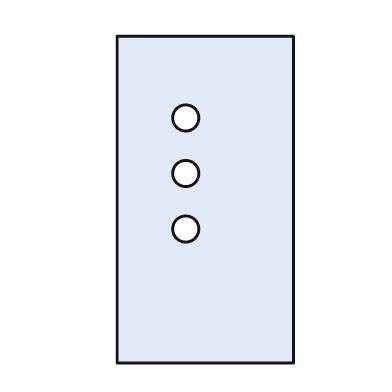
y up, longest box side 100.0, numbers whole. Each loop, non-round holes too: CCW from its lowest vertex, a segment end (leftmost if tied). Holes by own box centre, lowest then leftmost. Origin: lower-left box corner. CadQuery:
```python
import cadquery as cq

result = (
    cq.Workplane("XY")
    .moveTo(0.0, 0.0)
    .lineTo(54.0, 0.0)
    .lineTo(54.0, 100.0)
    .lineTo(0.0, 100.0)
    .close()
    .moveTo(21.0, 41.0)
    .circle(4.0)
    .moveTo(21.0, 58.0)
    .circle(4.0)
    .moveTo(21.0, 75.0)
    .circle(4.0)
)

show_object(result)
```